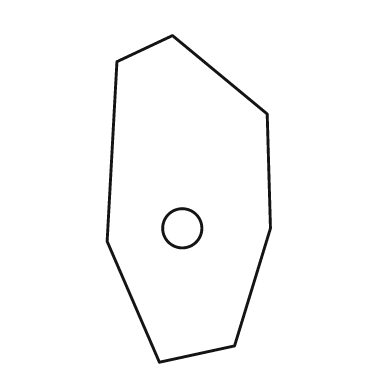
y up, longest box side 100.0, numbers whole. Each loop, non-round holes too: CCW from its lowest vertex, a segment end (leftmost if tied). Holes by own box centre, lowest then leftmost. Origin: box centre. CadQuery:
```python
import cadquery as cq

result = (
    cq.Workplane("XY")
    .moveTo(-9.0, -50.0)
    .lineTo(14.0, -45.0)
    .lineTo(25.0, -9.0)
    .lineTo(24.0, 26.0)
    .lineTo(-5.0, 50.0)
    .lineTo(-22.0, 42.0)
    .lineTo(-25.0, -13.0)
    .close()
    .moveTo(-2.0, -9.0)
    .circle(6.0)
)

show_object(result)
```